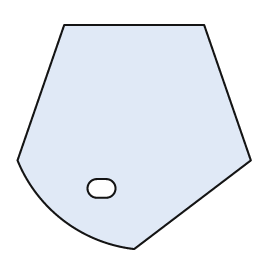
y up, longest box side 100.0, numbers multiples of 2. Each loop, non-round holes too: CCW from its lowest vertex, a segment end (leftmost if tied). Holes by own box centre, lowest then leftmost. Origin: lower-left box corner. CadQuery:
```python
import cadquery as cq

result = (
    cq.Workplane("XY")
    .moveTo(50.0, 0.0)
    .lineTo(100.0, 38.0)
    .lineTo(80.0, 96.0)
    .lineTo(20.0, 96.0)
    .lineTo(0.0, 38.0)
    .threePointArc((20.0, 12.0), (50.0, 0.0))
    .close()
    .moveTo(34.0, 22.0)
    .lineTo(38.0, 22.0)
    .threePointArc((42.0, 26.0), (38.0, 30.0))
    .lineTo(34.0, 30.0)
    .threePointArc((30.0, 26.0), (34.0, 22.0))
    .close()
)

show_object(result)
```